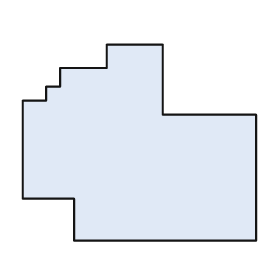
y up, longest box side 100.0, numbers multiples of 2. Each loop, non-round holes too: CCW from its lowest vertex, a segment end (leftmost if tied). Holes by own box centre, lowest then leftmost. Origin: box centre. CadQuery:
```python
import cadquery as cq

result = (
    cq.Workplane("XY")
    .moveTo(-28.0, -42.0)
    .lineTo(50.0, -42.0)
    .lineTo(50.0, 12.0)
    .lineTo(10.0, 12.0)
    .lineTo(10.0, 42.0)
    .lineTo(-14.0, 42.0)
    .lineTo(-14.0, 32.0)
    .lineTo(-34.0, 32.0)
    .lineTo(-34.0, 24.0)
    .lineTo(-40.0, 24.0)
    .lineTo(-40.0, 18.0)
    .lineTo(-50.0, 18.0)
    .lineTo(-50.0, -24.0)
    .lineTo(-28.0, -24.0)
    .close()
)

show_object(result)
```